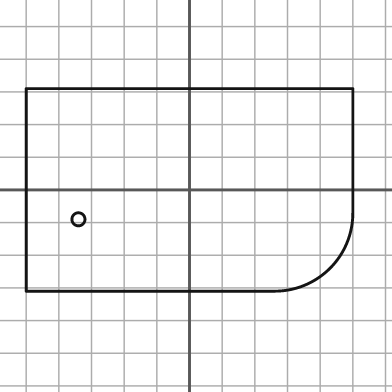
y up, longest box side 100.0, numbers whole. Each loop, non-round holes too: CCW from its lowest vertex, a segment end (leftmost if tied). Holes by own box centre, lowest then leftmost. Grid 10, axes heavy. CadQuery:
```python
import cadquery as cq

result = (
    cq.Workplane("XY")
    .moveTo(-50.0, -31.0)
    .lineTo(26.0, -31.0)
    .threePointArc((43.0, -24.0), (50.0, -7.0))
    .lineTo(50.0, 31.0)
    .lineTo(-50.0, 31.0)
    .close()
    .moveTo(-34.0, -9.0)
    .circle(2.0)
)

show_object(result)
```